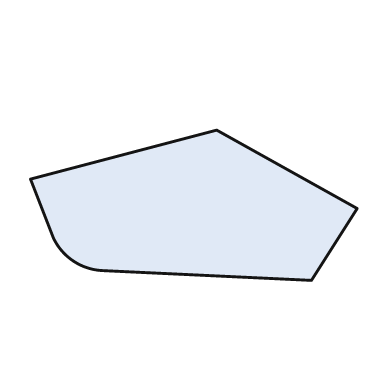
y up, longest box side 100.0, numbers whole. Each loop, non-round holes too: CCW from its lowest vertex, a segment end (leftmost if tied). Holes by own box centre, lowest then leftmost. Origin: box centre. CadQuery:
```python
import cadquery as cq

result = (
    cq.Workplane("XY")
    .moveTo(36.0, -23.0)
    .lineTo(50.0, -1.0)
    .lineTo(7.0, 23.0)
    .lineTo(-50.0, 8.0)
    .lineTo(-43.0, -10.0)
    .threePointArc((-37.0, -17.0), (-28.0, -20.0))
    .close()
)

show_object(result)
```